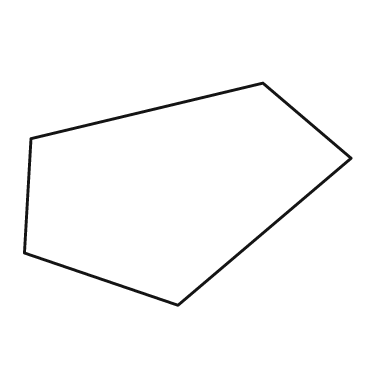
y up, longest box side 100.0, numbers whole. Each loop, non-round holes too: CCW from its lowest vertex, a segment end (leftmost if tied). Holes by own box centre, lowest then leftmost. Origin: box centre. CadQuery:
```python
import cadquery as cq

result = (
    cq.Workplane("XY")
    .moveTo(-3.0, -34.0)
    .lineTo(50.0, 11.0)
    .lineTo(23.0, 34.0)
    .lineTo(-48.0, 17.0)
    .lineTo(-50.0, -18.0)
    .close()
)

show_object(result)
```